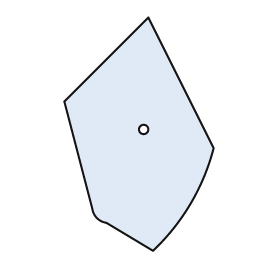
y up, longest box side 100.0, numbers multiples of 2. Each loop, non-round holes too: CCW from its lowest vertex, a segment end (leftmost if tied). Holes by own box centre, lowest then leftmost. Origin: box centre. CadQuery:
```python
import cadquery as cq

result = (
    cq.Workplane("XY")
    .moveTo(6.0, -50.0)
    .threePointArc((22.0, -30.0), (32.0, -6.0))
    .lineTo(4.0, 50.0)
    .lineTo(-32.0, 14.0)
    .lineTo(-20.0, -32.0)
    .threePointArc((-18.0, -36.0), (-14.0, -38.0))
    .close()
    .moveTo(2.0, 2.0)
    .circle(2.0)
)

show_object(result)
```